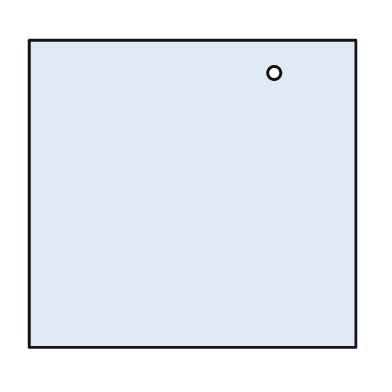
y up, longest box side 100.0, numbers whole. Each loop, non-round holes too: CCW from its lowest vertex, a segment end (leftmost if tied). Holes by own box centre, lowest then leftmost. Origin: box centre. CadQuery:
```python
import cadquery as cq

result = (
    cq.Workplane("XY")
    .moveTo(-50.0, -47.0)
    .lineTo(50.0, -47.0)
    .lineTo(50.0, 47.0)
    .lineTo(-50.0, 47.0)
    .close()
    .moveTo(25.0, 37.0)
    .circle(2.0)
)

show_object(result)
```